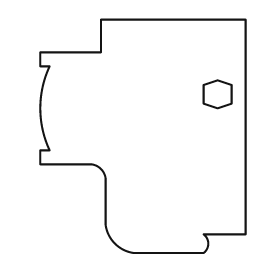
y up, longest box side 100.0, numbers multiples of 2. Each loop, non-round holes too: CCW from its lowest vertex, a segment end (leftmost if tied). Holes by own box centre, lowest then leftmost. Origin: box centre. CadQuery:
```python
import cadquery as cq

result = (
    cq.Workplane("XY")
    .moveTo(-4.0, -50.0)
    .lineTo(26.0, -50.0)
    .threePointArc((28.0, -46.0), (26.0, -42.0))
    .lineTo(44.0, -42.0)
    .lineTo(44.0, 50.0)
    .lineTo(-18.0, 50.0)
    .lineTo(-18.0, 36.0)
    .lineTo(-44.0, 36.0)
    .lineTo(-44.0, 30.0)
    .lineTo(-40.0, 30.0)
    .threePointArc((-44.0, 12.0), (-40.0, -6.0))
    .lineTo(-44.0, -6.0)
    .lineTo(-44.0, -12.0)
    .lineTo(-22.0, -12.0)
    .threePointArc((-18.0, -14.0), (-16.0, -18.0))
    .lineTo(-16.0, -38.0)
    .threePointArc((-12.0, -46.0), (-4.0, -50.0))
    .close()
    .moveTo(32.0, 12.0)
    .lineTo(38.0, 14.0)
    .lineTo(38.0, 22.0)
    .lineTo(32.0, 24.0)
    .lineTo(26.0, 22.0)
    .lineTo(26.0, 14.0)
    .close()
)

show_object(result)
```